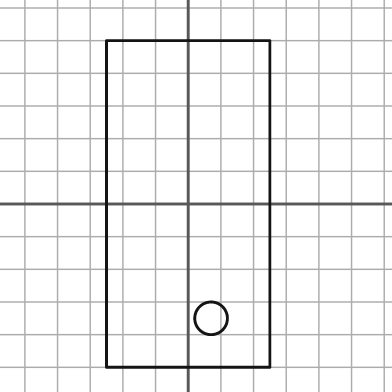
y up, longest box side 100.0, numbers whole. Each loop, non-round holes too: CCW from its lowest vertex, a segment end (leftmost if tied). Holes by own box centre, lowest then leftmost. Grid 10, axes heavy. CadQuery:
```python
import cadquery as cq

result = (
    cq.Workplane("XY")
    .moveTo(-25.0, -50.0)
    .lineTo(25.0, -50.0)
    .lineTo(25.0, 50.0)
    .lineTo(-25.0, 50.0)
    .close()
    .moveTo(7.0, -35.0)
    .circle(5.0)
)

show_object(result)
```